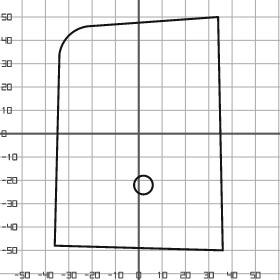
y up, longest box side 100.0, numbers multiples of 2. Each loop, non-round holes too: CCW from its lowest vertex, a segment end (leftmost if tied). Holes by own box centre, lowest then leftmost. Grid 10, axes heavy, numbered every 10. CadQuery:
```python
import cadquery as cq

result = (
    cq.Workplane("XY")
    .moveTo(36.0, -50.0)
    .lineTo(34.0, 50.0)
    .lineTo(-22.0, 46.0)
    .threePointArc((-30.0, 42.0), (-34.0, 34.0))
    .lineTo(-36.0, -48.0)
    .close()
    .moveTo(2.0, -22.0)
    .circle(4.0)
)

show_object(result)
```